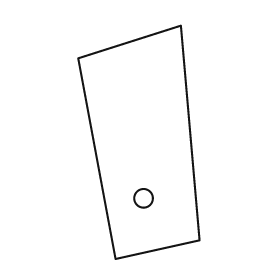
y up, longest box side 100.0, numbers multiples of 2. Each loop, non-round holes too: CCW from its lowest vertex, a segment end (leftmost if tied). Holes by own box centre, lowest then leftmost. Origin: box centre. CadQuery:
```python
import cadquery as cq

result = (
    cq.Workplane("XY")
    .moveTo(-10.0, -50.0)
    .lineTo(26.0, -42.0)
    .lineTo(18.0, 50.0)
    .lineTo(-26.0, 36.0)
    .close()
    .moveTo(2.0, -24.0)
    .circle(4.0)
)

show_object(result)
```